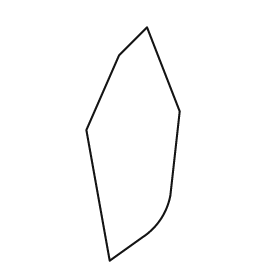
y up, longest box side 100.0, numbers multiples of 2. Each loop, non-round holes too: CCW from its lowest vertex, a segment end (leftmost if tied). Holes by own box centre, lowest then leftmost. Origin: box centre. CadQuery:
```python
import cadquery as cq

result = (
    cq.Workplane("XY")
    .moveTo(-10.0, -50.0)
    .lineTo(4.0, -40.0)
    .threePointArc((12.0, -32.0), (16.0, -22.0))
    .lineTo(20.0, 14.0)
    .lineTo(6.0, 50.0)
    .lineTo(-6.0, 38.0)
    .lineTo(-20.0, 6.0)
    .close()
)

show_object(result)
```